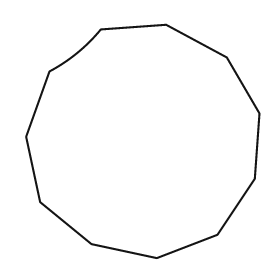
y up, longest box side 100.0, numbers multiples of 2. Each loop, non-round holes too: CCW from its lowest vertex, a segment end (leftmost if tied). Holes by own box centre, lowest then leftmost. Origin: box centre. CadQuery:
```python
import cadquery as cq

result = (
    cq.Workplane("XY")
    .moveTo(6.0, -50.0)
    .lineTo(32.0, -40.0)
    .lineTo(48.0, -16.0)
    .lineTo(50.0, 12.0)
    .lineTo(36.0, 36.0)
    .lineTo(10.0, 50.0)
    .lineTo(-18.0, 48.0)
    .threePointArc((-28.0, 38.0), (-40.0, 30.0))
    .lineTo(-50.0, 2.0)
    .lineTo(-44.0, -26.0)
    .lineTo(-22.0, -44.0)
    .close()
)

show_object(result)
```